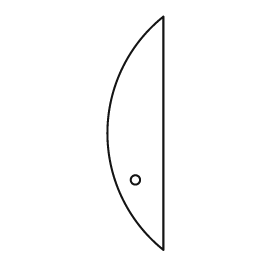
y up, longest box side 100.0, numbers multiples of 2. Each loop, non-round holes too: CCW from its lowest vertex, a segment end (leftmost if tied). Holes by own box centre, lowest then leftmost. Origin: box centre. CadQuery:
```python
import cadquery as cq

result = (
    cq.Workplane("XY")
    .moveTo(12.0, -50.0)
    .lineTo(12.0, 50.0)
    .threePointArc((-12.0, 0.0), (12.0, -50.0))
    .close()
    .moveTo(0.0, -20.0)
    .circle(2.0)
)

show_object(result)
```